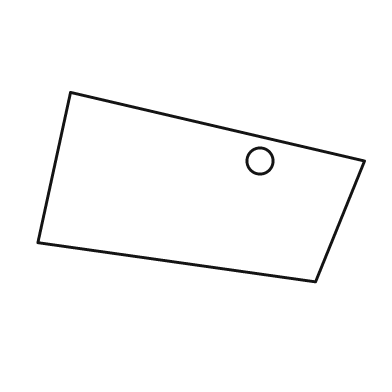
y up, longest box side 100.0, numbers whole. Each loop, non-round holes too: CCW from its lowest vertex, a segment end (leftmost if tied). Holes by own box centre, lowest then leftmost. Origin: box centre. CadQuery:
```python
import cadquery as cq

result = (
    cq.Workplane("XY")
    .moveTo(35.0, -29.0)
    .lineTo(50.0, 8.0)
    .lineTo(-40.0, 29.0)
    .lineTo(-50.0, -17.0)
    .close()
    .moveTo(18.0, 8.0)
    .circle(4.0)
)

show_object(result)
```